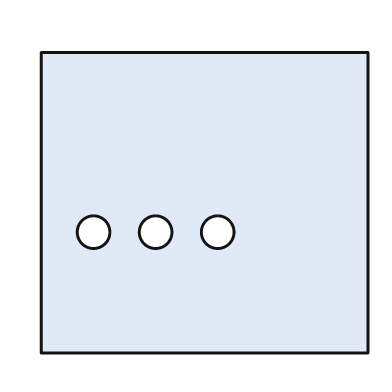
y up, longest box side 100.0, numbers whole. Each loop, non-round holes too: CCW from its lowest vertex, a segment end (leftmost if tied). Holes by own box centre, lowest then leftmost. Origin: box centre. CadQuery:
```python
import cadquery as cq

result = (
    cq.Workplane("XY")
    .moveTo(-50.0, -46.0)
    .lineTo(50.0, -46.0)
    .lineTo(50.0, 46.0)
    .lineTo(-50.0, 46.0)
    .close()
    .moveTo(-34.0, -9.0)
    .circle(5.0)
    .moveTo(-15.0, -9.0)
    .circle(5.0)
    .moveTo(4.0, -9.0)
    .circle(5.0)
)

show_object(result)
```